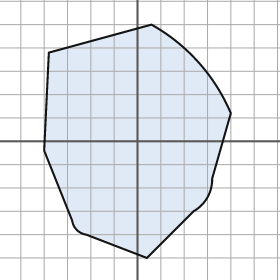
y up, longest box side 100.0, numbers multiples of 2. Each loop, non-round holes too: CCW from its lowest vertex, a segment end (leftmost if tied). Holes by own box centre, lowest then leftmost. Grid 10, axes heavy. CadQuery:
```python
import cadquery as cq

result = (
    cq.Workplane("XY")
    .moveTo(4.0, -50.0)
    .lineTo(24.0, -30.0)
    .threePointArc((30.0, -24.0), (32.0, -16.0))
    .lineTo(40.0, 12.0)
    .threePointArc((26.0, 34.0), (6.0, 50.0))
    .lineTo(-38.0, 38.0)
    .lineTo(-40.0, -4.0)
    .lineTo(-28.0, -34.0)
    .threePointArc((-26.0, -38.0), (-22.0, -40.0))
    .close()
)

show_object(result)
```